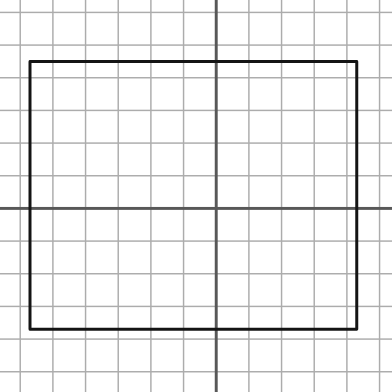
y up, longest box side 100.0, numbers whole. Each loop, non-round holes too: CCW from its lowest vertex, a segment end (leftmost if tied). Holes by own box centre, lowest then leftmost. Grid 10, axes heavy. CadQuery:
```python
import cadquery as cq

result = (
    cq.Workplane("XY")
    .moveTo(-57.0, -37.0)
    .lineTo(43.0, -37.0)
    .lineTo(43.0, 45.0)
    .lineTo(-57.0, 45.0)
    .close()
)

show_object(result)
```